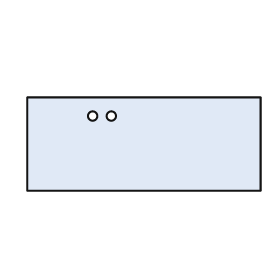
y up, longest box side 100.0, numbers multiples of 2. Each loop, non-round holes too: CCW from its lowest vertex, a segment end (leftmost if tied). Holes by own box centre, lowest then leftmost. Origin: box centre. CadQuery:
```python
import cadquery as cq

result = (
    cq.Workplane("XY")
    .moveTo(-50.0, -20.0)
    .lineTo(50.0, -20.0)
    .lineTo(50.0, 20.0)
    .lineTo(-50.0, 20.0)
    .close()
    .moveTo(-22.0, 12.0)
    .circle(2.0)
    .moveTo(-14.0, 12.0)
    .circle(2.0)
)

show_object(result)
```